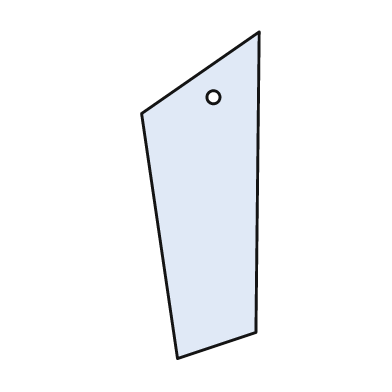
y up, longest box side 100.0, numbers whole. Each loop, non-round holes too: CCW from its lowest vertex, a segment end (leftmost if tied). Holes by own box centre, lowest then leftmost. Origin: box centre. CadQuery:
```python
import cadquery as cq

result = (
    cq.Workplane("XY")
    .moveTo(-7.0, -50.0)
    .lineTo(17.0, -42.0)
    .lineTo(18.0, 50.0)
    .lineTo(-18.0, 25.0)
    .close()
    .moveTo(4.0, 30.0)
    .circle(2.0)
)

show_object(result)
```